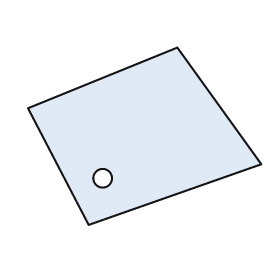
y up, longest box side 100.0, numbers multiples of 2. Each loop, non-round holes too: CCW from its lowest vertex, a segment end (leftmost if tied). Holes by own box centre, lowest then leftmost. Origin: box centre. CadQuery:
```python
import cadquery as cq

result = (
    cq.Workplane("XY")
    .moveTo(-24.0, -38.0)
    .lineTo(50.0, -12.0)
    .lineTo(14.0, 38.0)
    .lineTo(-50.0, 12.0)
    .close()
    .moveTo(-18.0, -18.0)
    .circle(4.0)
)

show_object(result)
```